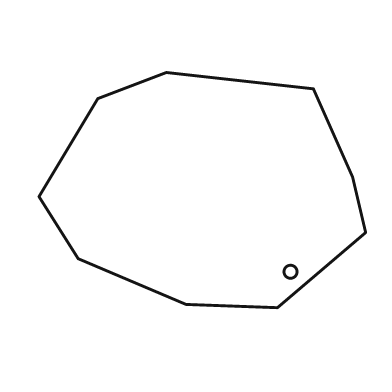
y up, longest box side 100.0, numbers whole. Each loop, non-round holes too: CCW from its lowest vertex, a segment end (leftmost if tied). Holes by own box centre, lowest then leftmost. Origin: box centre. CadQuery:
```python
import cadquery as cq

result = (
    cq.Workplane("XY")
    .moveTo(23.0, -36.0)
    .lineTo(50.0, -13.0)
    .lineTo(46.0, 4.0)
    .lineTo(34.0, 31.0)
    .lineTo(-11.0, 36.0)
    .lineTo(-32.0, 28.0)
    .lineTo(-50.0, -2.0)
    .lineTo(-38.0, -21.0)
    .lineTo(-5.0, -35.0)
    .close()
    .moveTo(27.0, -25.0)
    .circle(2.0)
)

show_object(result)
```